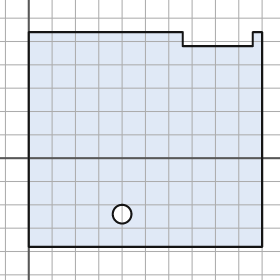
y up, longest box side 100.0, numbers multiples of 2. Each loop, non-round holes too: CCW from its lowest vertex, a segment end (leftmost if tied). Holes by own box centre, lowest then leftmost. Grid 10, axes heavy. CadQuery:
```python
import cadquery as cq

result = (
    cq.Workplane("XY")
    .moveTo(0.0, -38.0)
    .lineTo(100.0, -38.0)
    .lineTo(100.0, 54.0)
    .lineTo(96.0, 54.0)
    .lineTo(96.0, 48.0)
    .lineTo(66.0, 48.0)
    .lineTo(66.0, 54.0)
    .lineTo(0.0, 54.0)
    .close()
    .moveTo(40.0, -24.0)
    .circle(4.0)
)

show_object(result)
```